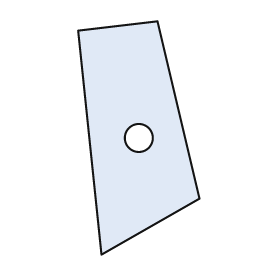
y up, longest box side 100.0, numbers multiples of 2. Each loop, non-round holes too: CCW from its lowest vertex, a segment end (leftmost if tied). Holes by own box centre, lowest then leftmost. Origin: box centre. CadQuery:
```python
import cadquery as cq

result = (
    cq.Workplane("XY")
    .moveTo(-16.0, -50.0)
    .lineTo(26.0, -26.0)
    .lineTo(8.0, 50.0)
    .lineTo(-26.0, 46.0)
    .close()
    .moveTo(0.0, 0.0)
    .circle(6.0)
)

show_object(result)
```